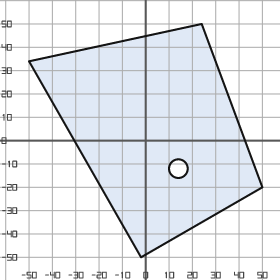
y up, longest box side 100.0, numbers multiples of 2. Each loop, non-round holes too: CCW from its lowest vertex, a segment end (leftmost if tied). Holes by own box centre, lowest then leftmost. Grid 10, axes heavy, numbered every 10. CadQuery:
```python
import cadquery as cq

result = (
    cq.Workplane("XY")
    .moveTo(-2.0, -50.0)
    .lineTo(50.0, -20.0)
    .lineTo(24.0, 50.0)
    .lineTo(-50.0, 34.0)
    .close()
    .moveTo(14.0, -12.0)
    .circle(4.0)
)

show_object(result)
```